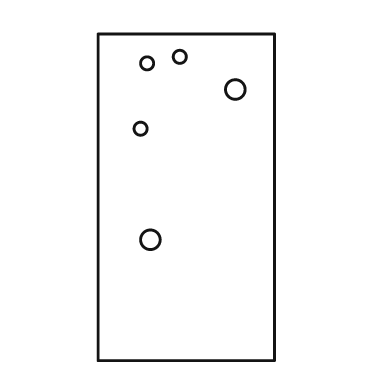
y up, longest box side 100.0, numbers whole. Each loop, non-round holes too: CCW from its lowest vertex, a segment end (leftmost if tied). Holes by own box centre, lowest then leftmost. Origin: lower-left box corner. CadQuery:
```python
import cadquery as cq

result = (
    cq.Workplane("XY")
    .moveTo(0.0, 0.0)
    .lineTo(54.0, 0.0)
    .lineTo(54.0, 100.0)
    .lineTo(0.0, 100.0)
    .close()
    .moveTo(16.0, 37.0)
    .circle(3.0)
    .moveTo(13.0, 71.0)
    .circle(2.0)
    .moveTo(42.0, 83.0)
    .circle(3.0)
    .moveTo(15.0, 91.0)
    .circle(2.0)
    .moveTo(25.0, 93.0)
    .circle(2.0)
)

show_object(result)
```